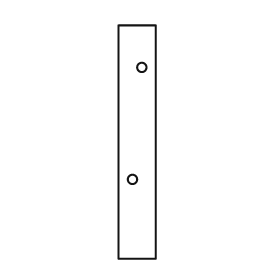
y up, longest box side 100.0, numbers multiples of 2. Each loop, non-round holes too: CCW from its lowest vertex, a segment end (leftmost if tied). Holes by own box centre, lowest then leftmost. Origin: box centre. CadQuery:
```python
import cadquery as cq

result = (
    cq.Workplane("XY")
    .moveTo(-8.0, -50.0)
    .lineTo(8.0, -50.0)
    .lineTo(8.0, 50.0)
    .lineTo(-8.0, 50.0)
    .close()
    .moveTo(-2.0, -16.0)
    .circle(2.0)
    .moveTo(2.0, 32.0)
    .circle(2.0)
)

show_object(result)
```